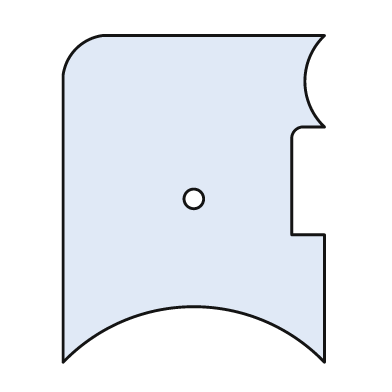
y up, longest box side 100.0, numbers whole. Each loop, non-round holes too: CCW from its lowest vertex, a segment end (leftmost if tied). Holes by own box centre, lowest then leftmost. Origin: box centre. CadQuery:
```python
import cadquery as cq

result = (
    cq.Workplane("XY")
    .moveTo(-40.0, -50.0)
    .threePointArc((0.0, -33.0), (40.0, -50.0))
    .lineTo(40.0, -11.0)
    .lineTo(30.0, -11.0)
    .lineTo(30.0, 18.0)
    .threePointArc((31.0, 21.0), (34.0, 22.0))
    .lineTo(40.0, 22.0)
    .threePointArc((34.0, 36.0), (40.0, 50.0))
    .lineTo(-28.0, 50.0)
    .threePointArc((-36.0, 46.0), (-40.0, 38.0))
    .close()
    .moveTo(0.0, 0.0)
    .circle(3.0)
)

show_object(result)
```